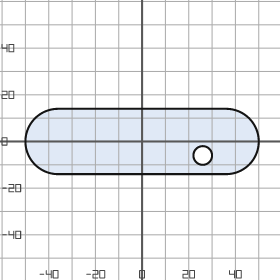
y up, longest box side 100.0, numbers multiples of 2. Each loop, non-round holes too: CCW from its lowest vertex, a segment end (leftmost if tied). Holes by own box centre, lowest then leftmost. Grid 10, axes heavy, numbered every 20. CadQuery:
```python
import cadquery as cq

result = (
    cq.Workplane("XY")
    .moveTo(-36.0, -14.0)
    .lineTo(36.0, -14.0)
    .threePointArc((50.0, 0.0), (36.0, 14.0))
    .lineTo(-36.0, 14.0)
    .threePointArc((-50.0, 0.0), (-36.0, -14.0))
    .close()
    .moveTo(26.0, -6.0)
    .circle(4.0)
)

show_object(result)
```